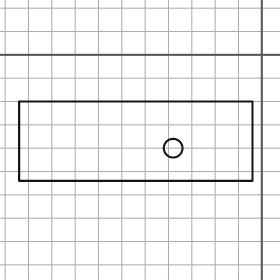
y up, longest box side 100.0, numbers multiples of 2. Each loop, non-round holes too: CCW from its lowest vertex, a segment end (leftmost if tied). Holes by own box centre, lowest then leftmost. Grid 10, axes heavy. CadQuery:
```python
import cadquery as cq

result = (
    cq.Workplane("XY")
    .moveTo(-104.0, -54.0)
    .lineTo(-4.0, -54.0)
    .lineTo(-4.0, -20.0)
    .lineTo(-104.0, -20.0)
    .close()
    .moveTo(-38.0, -40.0)
    .circle(4.0)
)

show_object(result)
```